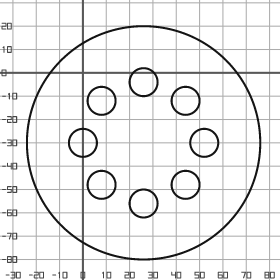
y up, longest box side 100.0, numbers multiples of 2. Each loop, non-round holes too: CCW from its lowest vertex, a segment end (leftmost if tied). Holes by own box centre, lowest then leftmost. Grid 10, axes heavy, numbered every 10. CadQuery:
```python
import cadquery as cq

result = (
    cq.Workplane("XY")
    .moveTo(26.0, -30.0)
    .circle(50.0)
    .moveTo(26.0, -56.0)
    .circle(6.0)
    .moveTo(8.0, -48.0)
    .circle(6.0)
    .moveTo(44.0, -48.0)
    .circle(6.0)
    .moveTo(0.0, -30.0)
    .circle(6.0)
    .moveTo(52.0, -30.0)
    .circle(6.0)
    .moveTo(8.0, -12.0)
    .circle(6.0)
    .moveTo(44.0, -12.0)
    .circle(6.0)
    .moveTo(26.0, -4.0)
    .circle(6.0)
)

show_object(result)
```